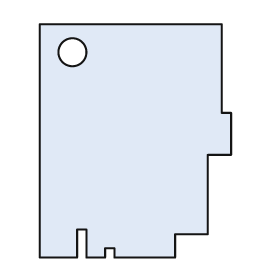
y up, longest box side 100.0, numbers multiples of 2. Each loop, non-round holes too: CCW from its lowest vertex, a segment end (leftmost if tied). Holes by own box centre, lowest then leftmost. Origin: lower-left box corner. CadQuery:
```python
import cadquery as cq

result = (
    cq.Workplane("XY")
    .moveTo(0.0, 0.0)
    .lineTo(16.0, 0.0)
    .lineTo(16.0, 12.0)
    .lineTo(20.0, 12.0)
    .lineTo(20.0, 0.0)
    .lineTo(28.0, 0.0)
    .lineTo(28.0, 4.0)
    .lineTo(32.0, 4.0)
    .lineTo(32.0, 0.0)
    .lineTo(58.0, 0.0)
    .lineTo(58.0, 10.0)
    .lineTo(72.0, 10.0)
    .lineTo(72.0, 44.0)
    .lineTo(82.0, 44.0)
    .lineTo(82.0, 62.0)
    .lineTo(78.0, 62.0)
    .lineTo(78.0, 100.0)
    .lineTo(0.0, 100.0)
    .close()
    .moveTo(14.0, 88.0)
    .circle(6.0)
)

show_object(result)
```